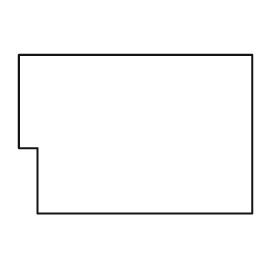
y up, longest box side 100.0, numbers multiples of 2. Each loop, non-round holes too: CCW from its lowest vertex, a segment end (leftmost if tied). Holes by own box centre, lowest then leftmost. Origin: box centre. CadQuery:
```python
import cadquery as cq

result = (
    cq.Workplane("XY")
    .moveTo(-42.0, -34.0)
    .lineTo(50.0, -34.0)
    .lineTo(50.0, 34.0)
    .lineTo(-50.0, 34.0)
    .lineTo(-50.0, -6.0)
    .lineTo(-42.0, -6.0)
    .close()
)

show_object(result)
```